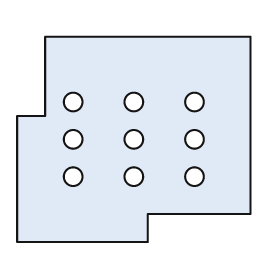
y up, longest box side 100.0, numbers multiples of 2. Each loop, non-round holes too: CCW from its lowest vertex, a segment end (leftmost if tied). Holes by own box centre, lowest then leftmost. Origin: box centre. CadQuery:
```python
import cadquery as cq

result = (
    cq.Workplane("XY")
    .moveTo(-50.0, -44.0)
    .lineTo(6.0, -44.0)
    .lineTo(6.0, -32.0)
    .lineTo(50.0, -32.0)
    .lineTo(50.0, 44.0)
    .lineTo(-38.0, 44.0)
    .lineTo(-38.0, 10.0)
    .lineTo(-50.0, 10.0)
    .close()
    .moveTo(-26.0, -16.0)
    .circle(4.0)
    .moveTo(0.0, -16.0)
    .circle(4.0)
    .moveTo(26.0, -16.0)
    .circle(4.0)
    .moveTo(-26.0, 0.0)
    .circle(4.0)
    .moveTo(0.0, 0.0)
    .circle(4.0)
    .moveTo(26.0, 0.0)
    .circle(4.0)
    .moveTo(-26.0, 16.0)
    .circle(4.0)
    .moveTo(0.0, 16.0)
    .circle(4.0)
    .moveTo(26.0, 16.0)
    .circle(4.0)
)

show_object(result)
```